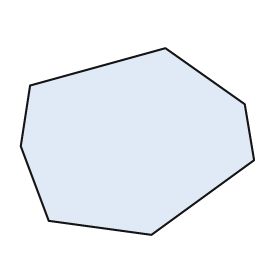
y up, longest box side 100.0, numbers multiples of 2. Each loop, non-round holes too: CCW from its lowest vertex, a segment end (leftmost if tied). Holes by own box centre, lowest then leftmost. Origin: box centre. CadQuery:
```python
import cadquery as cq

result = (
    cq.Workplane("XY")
    .moveTo(6.0, -40.0)
    .lineTo(50.0, -8.0)
    .lineTo(46.0, 16.0)
    .lineTo(12.0, 40.0)
    .lineTo(-46.0, 24.0)
    .lineTo(-50.0, -2.0)
    .lineTo(-38.0, -34.0)
    .close()
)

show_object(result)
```